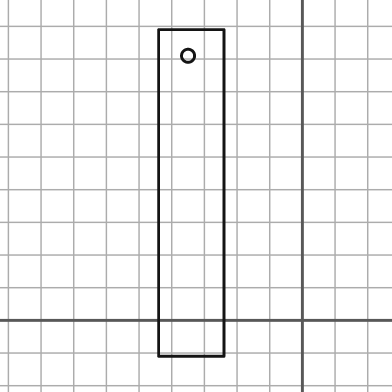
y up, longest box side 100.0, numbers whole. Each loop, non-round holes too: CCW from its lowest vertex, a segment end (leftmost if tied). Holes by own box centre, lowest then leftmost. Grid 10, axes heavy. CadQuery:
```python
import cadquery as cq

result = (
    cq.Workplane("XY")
    .moveTo(-44.0, -11.0)
    .lineTo(-24.0, -11.0)
    .lineTo(-24.0, 89.0)
    .lineTo(-44.0, 89.0)
    .close()
    .moveTo(-35.0, 81.0)
    .circle(2.0)
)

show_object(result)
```